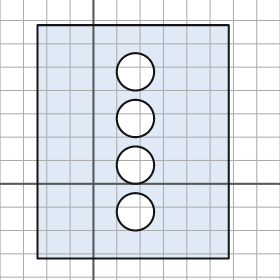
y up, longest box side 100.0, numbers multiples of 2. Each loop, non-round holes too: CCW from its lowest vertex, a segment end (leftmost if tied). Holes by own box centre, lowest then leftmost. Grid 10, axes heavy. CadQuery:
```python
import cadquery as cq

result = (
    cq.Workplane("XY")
    .moveTo(-24.0, -32.0)
    .lineTo(58.0, -32.0)
    .lineTo(58.0, 68.0)
    .lineTo(-24.0, 68.0)
    .close()
    .moveTo(18.0, -12.0)
    .circle(8.0)
    .moveTo(18.0, 8.0)
    .circle(8.0)
    .moveTo(18.0, 28.0)
    .circle(8.0)
    .moveTo(18.0, 48.0)
    .circle(8.0)
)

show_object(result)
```